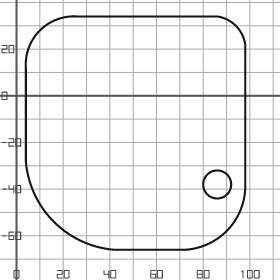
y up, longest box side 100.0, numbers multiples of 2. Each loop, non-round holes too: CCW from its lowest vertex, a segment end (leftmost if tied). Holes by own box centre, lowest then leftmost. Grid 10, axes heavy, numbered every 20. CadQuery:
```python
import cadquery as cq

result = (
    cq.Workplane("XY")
    .moveTo(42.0, -66.0)
    .lineTo(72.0, -66.0)
    .threePointArc((90.0, -58.0), (98.0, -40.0))
    .lineTo(98.0, 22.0)
    .threePointArc((94.0, 30.0), (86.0, 34.0))
    .lineTo(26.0, 34.0)
    .threePointArc((10.0, 28.0), (4.0, 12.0))
    .lineTo(4.0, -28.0)
    .threePointArc((16.0, -54.0), (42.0, -66.0))
    .close()
    .moveTo(86.0, -38.0)
    .circle(6.0)
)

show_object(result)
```